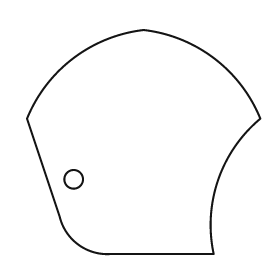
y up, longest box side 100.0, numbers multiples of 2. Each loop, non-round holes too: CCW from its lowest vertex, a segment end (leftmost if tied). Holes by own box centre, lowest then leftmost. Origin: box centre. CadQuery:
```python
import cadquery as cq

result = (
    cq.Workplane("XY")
    .moveTo(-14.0, -48.0)
    .lineTo(30.0, -48.0)
    .threePointArc((32.0, -16.0), (50.0, 10.0))
    .threePointArc((30.0, 36.0), (0.0, 48.0))
    .threePointArc((-30.0, 36.0), (-50.0, 10.0))
    .lineTo(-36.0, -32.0)
    .threePointArc((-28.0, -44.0), (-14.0, -48.0))
    .close()
    .moveTo(-30.0, -16.0)
    .circle(4.0)
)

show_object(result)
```